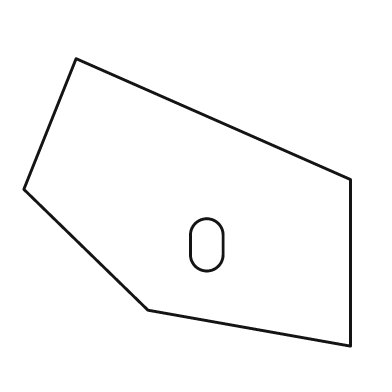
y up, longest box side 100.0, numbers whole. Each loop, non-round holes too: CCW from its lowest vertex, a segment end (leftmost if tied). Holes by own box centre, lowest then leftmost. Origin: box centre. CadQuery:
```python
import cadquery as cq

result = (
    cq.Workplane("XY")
    .moveTo(50.0, -44.0)
    .lineTo(50.0, 7.0)
    .lineTo(-34.0, 44.0)
    .lineTo(-50.0, 4.0)
    .lineTo(-12.0, -33.0)
    .close()
    .moveTo(1.0, -16.0)
    .threePointArc((6.0, -21.0), (11.0, -16.0))
    .lineTo(11.0, -10.0)
    .threePointArc((6.0, -5.0), (1.0, -10.0))
    .close()
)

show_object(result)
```